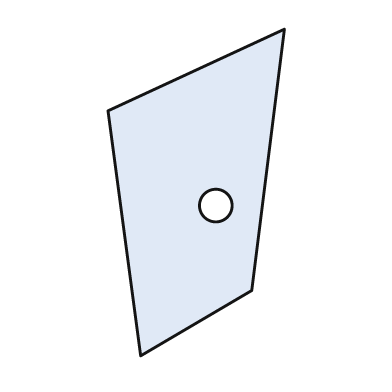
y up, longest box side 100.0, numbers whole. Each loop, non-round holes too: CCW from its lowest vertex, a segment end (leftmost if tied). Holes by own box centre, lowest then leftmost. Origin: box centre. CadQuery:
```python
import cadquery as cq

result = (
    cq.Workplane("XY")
    .moveTo(-17.0, -50.0)
    .lineTo(17.0, -30.0)
    .lineTo(27.0, 50.0)
    .lineTo(-27.0, 25.0)
    .close()
    .moveTo(6.0, -4.0)
    .circle(5.0)
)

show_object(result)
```